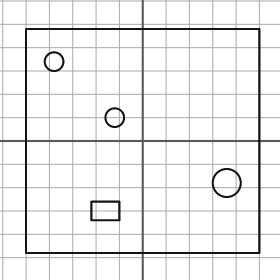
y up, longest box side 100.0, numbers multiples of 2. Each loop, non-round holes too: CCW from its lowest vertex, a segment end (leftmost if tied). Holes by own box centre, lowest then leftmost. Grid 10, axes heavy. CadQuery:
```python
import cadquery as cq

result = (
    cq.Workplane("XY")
    .moveTo(-50.0, -48.0)
    .lineTo(50.0, -48.0)
    .lineTo(50.0, 48.0)
    .lineTo(-50.0, 48.0)
    .close()
    .moveTo(-22.0, -34.0)
    .lineTo(-10.0, -34.0)
    .lineTo(-10.0, -26.0)
    .lineTo(-22.0, -26.0)
    .close()
    .moveTo(36.0, -18.0)
    .circle(6.0)
    .moveTo(-12.0, 10.0)
    .circle(4.0)
    .moveTo(-38.0, 34.0)
    .circle(4.0)
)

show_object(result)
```